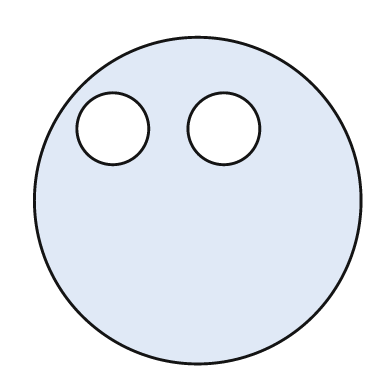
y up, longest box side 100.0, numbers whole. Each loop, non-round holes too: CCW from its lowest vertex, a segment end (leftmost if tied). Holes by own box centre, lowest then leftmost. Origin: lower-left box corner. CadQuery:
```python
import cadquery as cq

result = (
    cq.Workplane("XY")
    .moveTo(50.0, 50.0)
    .circle(50.0)
    .moveTo(24.0, 72.0)
    .circle(11.0)
    .moveTo(58.0, 72.0)
    .circle(11.0)
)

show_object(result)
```